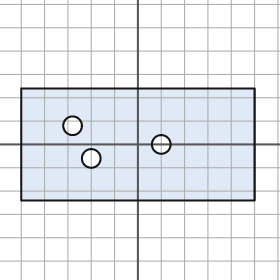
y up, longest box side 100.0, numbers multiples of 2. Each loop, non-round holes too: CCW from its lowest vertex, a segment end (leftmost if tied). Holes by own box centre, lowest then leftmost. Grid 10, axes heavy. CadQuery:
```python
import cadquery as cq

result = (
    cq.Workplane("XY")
    .moveTo(-50.0, -24.0)
    .lineTo(50.0, -24.0)
    .lineTo(50.0, 24.0)
    .lineTo(-50.0, 24.0)
    .close()
    .moveTo(-20.0, -6.0)
    .circle(4.0)
    .moveTo(10.0, 0.0)
    .circle(4.0)
    .moveTo(-28.0, 8.0)
    .circle(4.0)
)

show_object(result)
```